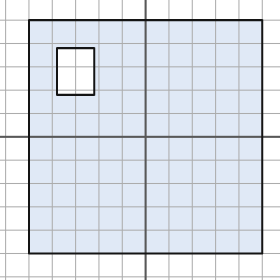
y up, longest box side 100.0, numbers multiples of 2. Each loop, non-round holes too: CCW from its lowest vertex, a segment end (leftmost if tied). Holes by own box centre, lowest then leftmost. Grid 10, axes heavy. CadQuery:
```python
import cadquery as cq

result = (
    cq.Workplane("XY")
    .moveTo(-50.0, -50.0)
    .lineTo(50.0, -50.0)
    .lineTo(50.0, 50.0)
    .lineTo(-50.0, 50.0)
    .close()
    .moveTo(-38.0, 18.0)
    .lineTo(-22.0, 18.0)
    .lineTo(-22.0, 38.0)
    .lineTo(-38.0, 38.0)
    .close()
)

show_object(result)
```